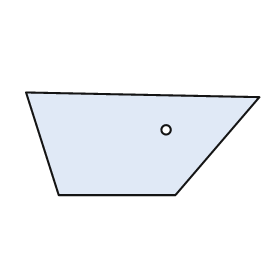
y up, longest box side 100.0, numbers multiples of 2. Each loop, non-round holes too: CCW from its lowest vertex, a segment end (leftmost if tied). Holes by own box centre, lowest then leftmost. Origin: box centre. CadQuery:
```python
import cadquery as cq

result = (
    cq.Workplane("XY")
    .moveTo(-36.0, -22.0)
    .lineTo(14.0, -22.0)
    .lineTo(50.0, 20.0)
    .lineTo(-50.0, 22.0)
    .close()
    .moveTo(10.0, 6.0)
    .circle(2.0)
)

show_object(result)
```